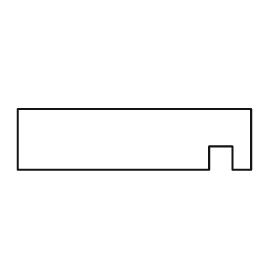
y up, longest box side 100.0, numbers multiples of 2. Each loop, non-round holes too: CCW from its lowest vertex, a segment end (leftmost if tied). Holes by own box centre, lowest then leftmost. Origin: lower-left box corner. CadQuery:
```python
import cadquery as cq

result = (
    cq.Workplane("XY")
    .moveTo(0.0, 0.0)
    .lineTo(82.0, 0.0)
    .lineTo(82.0, 10.0)
    .lineTo(92.0, 10.0)
    .lineTo(92.0, 0.0)
    .lineTo(100.0, 0.0)
    .lineTo(100.0, 26.0)
    .lineTo(0.0, 26.0)
    .close()
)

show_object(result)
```